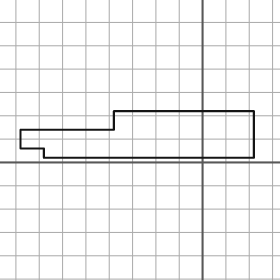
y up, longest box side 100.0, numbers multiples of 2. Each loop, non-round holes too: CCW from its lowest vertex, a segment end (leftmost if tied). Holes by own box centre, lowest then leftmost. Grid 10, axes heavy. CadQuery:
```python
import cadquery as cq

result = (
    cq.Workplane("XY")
    .moveTo(-68.0, 2.0)
    .lineTo(22.0, 2.0)
    .lineTo(22.0, 22.0)
    .lineTo(-38.0, 22.0)
    .lineTo(-38.0, 14.0)
    .lineTo(-78.0, 14.0)
    .lineTo(-78.0, 6.0)
    .lineTo(-68.0, 6.0)
    .close()
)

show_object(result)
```